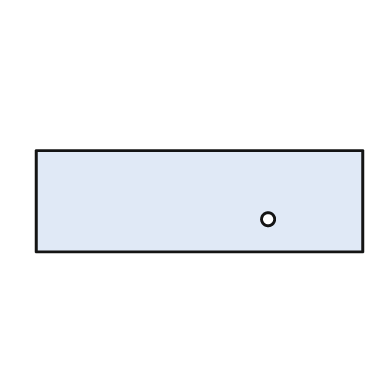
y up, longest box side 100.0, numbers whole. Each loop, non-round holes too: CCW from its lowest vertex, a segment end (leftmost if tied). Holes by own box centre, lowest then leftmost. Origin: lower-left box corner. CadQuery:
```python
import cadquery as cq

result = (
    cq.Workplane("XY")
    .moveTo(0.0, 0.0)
    .lineTo(100.0, 0.0)
    .lineTo(100.0, 31.0)
    .lineTo(0.0, 31.0)
    .close()
    .moveTo(71.0, 10.0)
    .circle(2.0)
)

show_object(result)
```